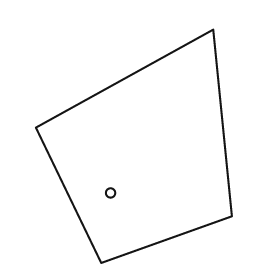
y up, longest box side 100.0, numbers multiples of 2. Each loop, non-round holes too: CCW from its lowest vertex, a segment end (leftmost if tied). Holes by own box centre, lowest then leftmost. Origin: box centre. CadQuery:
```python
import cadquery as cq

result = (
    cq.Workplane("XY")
    .moveTo(-14.0, -50.0)
    .lineTo(42.0, -30.0)
    .lineTo(34.0, 50.0)
    .lineTo(-42.0, 8.0)
    .close()
    .moveTo(-10.0, -20.0)
    .circle(2.0)
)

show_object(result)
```